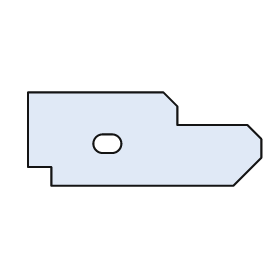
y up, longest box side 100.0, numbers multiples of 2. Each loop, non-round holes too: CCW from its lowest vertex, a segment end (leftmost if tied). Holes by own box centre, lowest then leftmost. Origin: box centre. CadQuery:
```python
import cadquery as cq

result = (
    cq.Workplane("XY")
    .moveTo(-40.0, -20.0)
    .lineTo(38.0, -20.0)
    .lineTo(50.0, -8.0)
    .lineTo(50.0, 0.0)
    .lineTo(44.0, 6.0)
    .lineTo(14.0, 6.0)
    .lineTo(14.0, 14.0)
    .lineTo(8.0, 20.0)
    .lineTo(-50.0, 20.0)
    .lineTo(-50.0, -12.0)
    .lineTo(-40.0, -12.0)
    .close()
    .moveTo(-18.0, -6.0)
    .lineTo(-14.0, -6.0)
    .threePointArc((-10.0, -2.0), (-14.0, 2.0))
    .lineTo(-18.0, 2.0)
    .threePointArc((-22.0, -2.0), (-18.0, -6.0))
    .close()
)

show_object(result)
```